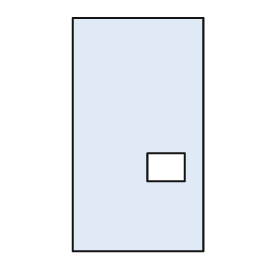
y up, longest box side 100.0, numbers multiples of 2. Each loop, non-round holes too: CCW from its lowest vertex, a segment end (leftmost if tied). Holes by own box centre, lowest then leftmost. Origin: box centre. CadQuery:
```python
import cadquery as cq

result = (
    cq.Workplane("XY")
    .moveTo(-28.0, -50.0)
    .lineTo(28.0, -50.0)
    .lineTo(28.0, 50.0)
    .lineTo(-28.0, 50.0)
    .close()
    .moveTo(4.0, -20.0)
    .lineTo(20.0, -20.0)
    .lineTo(20.0, -8.0)
    .lineTo(4.0, -8.0)
    .close()
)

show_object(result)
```